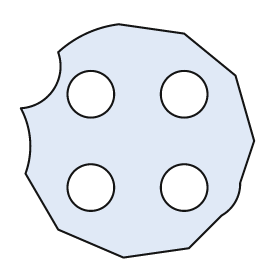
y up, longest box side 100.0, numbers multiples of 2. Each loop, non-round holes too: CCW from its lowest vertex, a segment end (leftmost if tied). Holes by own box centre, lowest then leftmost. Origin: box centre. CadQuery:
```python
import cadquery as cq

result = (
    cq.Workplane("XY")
    .moveTo(-6.0, -50.0)
    .lineTo(22.0, -46.0)
    .lineTo(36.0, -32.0)
    .threePointArc((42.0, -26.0), (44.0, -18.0))
    .lineTo(50.0, 0.0)
    .lineTo(42.0, 28.0)
    .lineTo(20.0, 46.0)
    .lineTo(-8.0, 50.0)
    .threePointArc((-22.0, 46.0), (-34.0, 38.0))
    .threePointArc((-36.0, 22.0), (-50.0, 14.0))
    .threePointArc((-46.0, 0.0), (-48.0, -14.0))
    .lineTo(-34.0, -38.0)
    .close()
    .moveTo(-20.0, -20.0)
    .circle(10.0)
    .moveTo(20.0, -20.0)
    .circle(10.0)
    .moveTo(-20.0, 20.0)
    .circle(10.0)
    .moveTo(20.0, 20.0)
    .circle(10.0)
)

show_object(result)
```